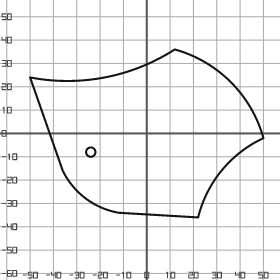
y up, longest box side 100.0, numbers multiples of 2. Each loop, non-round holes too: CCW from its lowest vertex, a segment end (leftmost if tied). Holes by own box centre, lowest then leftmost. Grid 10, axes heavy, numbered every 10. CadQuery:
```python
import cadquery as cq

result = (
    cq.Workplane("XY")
    .moveTo(22.0, -36.0)
    .threePointArc((32.0, -16.0), (50.0, -2.0))
    .threePointArc((36.0, 22.0), (12.0, 36.0))
    .threePointArc((-18.0, 24.0), (-50.0, 24.0))
    .lineTo(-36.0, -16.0)
    .threePointArc((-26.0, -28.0), (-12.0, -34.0))
    .close()
    .moveTo(-24.0, -8.0)
    .circle(2.0)
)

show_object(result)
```